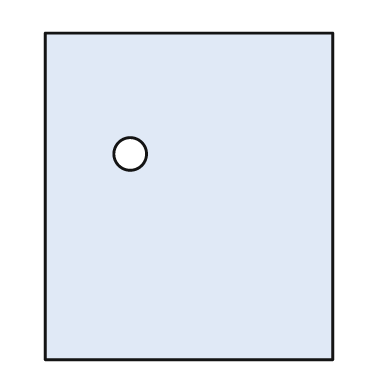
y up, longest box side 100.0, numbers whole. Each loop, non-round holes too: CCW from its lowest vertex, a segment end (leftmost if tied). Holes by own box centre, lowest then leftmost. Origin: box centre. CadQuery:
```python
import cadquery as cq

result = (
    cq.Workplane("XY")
    .moveTo(-44.0, -50.0)
    .lineTo(44.0, -50.0)
    .lineTo(44.0, 50.0)
    .lineTo(-44.0, 50.0)
    .close()
    .moveTo(-18.0, 13.0)
    .circle(5.0)
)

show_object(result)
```